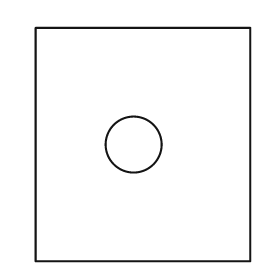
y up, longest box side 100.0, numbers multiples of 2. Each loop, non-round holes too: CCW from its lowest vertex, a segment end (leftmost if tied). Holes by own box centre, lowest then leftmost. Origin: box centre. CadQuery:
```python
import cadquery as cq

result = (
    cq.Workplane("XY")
    .moveTo(-46.0, -50.0)
    .lineTo(46.0, -50.0)
    .lineTo(46.0, 50.0)
    .lineTo(-46.0, 50.0)
    .close()
    .moveTo(-4.0, 0.0)
    .circle(12.0)
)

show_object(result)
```